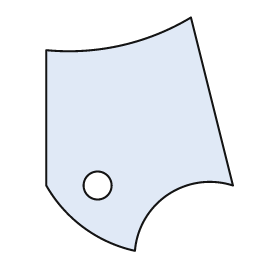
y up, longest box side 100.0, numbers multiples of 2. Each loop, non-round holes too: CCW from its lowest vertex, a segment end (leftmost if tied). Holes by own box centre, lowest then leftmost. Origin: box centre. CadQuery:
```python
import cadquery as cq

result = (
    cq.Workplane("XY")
    .moveTo(-2.0, -50.0)
    .threePointArc((12.0, -26.0), (40.0, -22.0))
    .lineTo(22.0, 50.0)
    .threePointArc((-8.0, 38.0), (-40.0, 36.0))
    .lineTo(-40.0, -22.0)
    .threePointArc((-24.0, -40.0), (-2.0, -50.0))
    .close()
    .moveTo(-18.0, -22.0)
    .circle(6.0)
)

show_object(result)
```